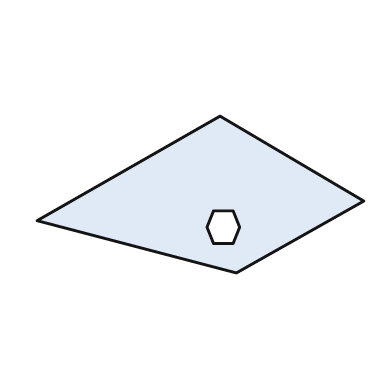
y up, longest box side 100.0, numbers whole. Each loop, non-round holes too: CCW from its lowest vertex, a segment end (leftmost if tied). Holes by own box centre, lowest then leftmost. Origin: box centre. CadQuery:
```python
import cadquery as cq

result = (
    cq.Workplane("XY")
    .moveTo(11.0, -24.0)
    .lineTo(50.0, -2.0)
    .lineTo(6.0, 24.0)
    .lineTo(-50.0, -8.0)
    .close()
    .moveTo(4.0, -15.0)
    .lineTo(10.0, -15.0)
    .lineTo(12.0, -10.0)
    .lineTo(10.0, -5.0)
    .lineTo(4.0, -5.0)
    .lineTo(2.0, -10.0)
    .close()
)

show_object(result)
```